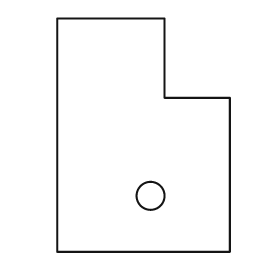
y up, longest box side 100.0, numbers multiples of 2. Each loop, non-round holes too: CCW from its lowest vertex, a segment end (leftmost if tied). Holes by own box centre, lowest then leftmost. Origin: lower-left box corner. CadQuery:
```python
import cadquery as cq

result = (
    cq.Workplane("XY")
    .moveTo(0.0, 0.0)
    .lineTo(74.0, 0.0)
    .lineTo(74.0, 66.0)
    .lineTo(46.0, 66.0)
    .lineTo(46.0, 100.0)
    .lineTo(0.0, 100.0)
    .close()
    .moveTo(40.0, 24.0)
    .circle(6.0)
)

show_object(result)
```